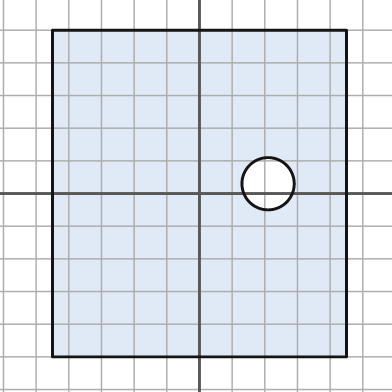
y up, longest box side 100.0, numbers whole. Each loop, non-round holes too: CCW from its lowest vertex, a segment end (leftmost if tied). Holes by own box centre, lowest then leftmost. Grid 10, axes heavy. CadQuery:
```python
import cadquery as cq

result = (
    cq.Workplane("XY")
    .moveTo(-45.0, -50.0)
    .lineTo(45.0, -50.0)
    .lineTo(45.0, 50.0)
    .lineTo(-45.0, 50.0)
    .close()
    .moveTo(21.0, 3.0)
    .circle(8.0)
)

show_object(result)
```